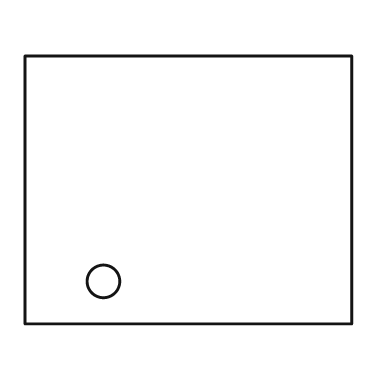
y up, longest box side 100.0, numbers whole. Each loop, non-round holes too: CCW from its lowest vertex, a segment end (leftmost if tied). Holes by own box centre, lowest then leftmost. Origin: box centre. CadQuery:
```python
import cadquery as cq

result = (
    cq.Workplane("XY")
    .moveTo(-50.0, -41.0)
    .lineTo(50.0, -41.0)
    .lineTo(50.0, 41.0)
    .lineTo(-50.0, 41.0)
    .close()
    .moveTo(-26.0, -28.0)
    .circle(5.0)
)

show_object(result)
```